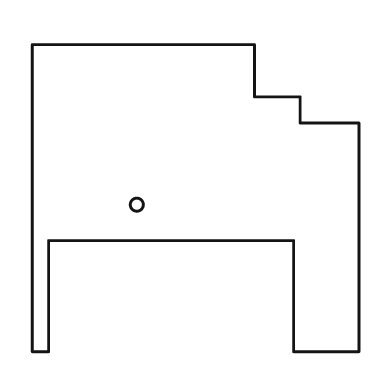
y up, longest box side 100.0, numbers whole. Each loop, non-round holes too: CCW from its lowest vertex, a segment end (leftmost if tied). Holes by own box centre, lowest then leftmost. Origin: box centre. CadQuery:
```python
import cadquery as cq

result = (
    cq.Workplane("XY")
    .moveTo(-50.0, -47.0)
    .lineTo(-45.0, -47.0)
    .lineTo(-45.0, -13.0)
    .lineTo(30.0, -13.0)
    .lineTo(30.0, -47.0)
    .lineTo(50.0, -47.0)
    .lineTo(50.0, 23.0)
    .lineTo(32.0, 23.0)
    .lineTo(32.0, 31.0)
    .lineTo(18.0, 31.0)
    .lineTo(18.0, 47.0)
    .lineTo(-50.0, 47.0)
    .close()
    .moveTo(-18.0, -2.0)
    .circle(2.0)
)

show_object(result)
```